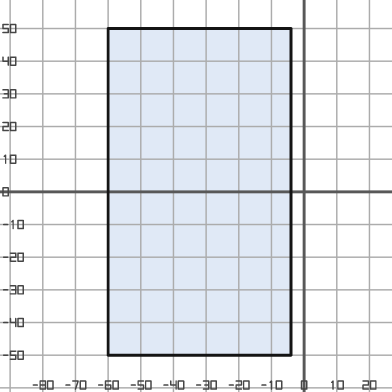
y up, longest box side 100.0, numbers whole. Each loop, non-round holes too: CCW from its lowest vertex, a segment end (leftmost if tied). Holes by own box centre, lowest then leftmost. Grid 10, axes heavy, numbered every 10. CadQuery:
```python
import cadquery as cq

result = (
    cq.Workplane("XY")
    .moveTo(-60.0, -50.0)
    .lineTo(-4.0, -50.0)
    .lineTo(-4.0, 50.0)
    .lineTo(-60.0, 50.0)
    .close()
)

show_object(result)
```